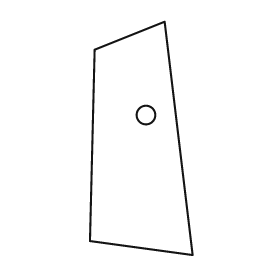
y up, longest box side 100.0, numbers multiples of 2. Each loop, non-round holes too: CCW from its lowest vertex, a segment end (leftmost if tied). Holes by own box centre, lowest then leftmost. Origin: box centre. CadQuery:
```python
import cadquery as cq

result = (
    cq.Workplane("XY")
    .moveTo(22.0, -50.0)
    .lineTo(10.0, 50.0)
    .lineTo(-20.0, 38.0)
    .lineTo(-22.0, -44.0)
    .close()
    .moveTo(2.0, 10.0)
    .circle(4.0)
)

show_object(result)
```